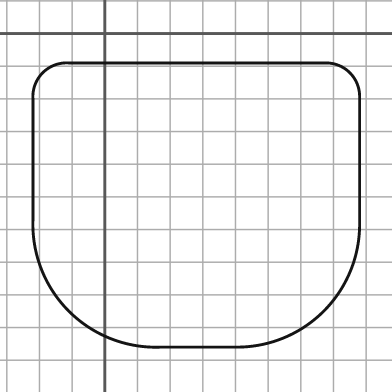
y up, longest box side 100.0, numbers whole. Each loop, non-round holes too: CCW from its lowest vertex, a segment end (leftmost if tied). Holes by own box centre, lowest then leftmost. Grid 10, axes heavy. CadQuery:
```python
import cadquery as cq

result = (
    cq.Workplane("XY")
    .moveTo(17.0, -96.0)
    .lineTo(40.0, -96.0)
    .threePointArc((67.0, -85.0), (78.0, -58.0))
    .lineTo(78.0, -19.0)
    .threePointArc((75.0, -12.0), (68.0, -9.0))
    .lineTo(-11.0, -9.0)
    .threePointArc((-19.0, -12.0), (-22.0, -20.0))
    .lineTo(-22.0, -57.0)
    .threePointArc((-11.0, -85.0), (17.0, -96.0))
    .close()
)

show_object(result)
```